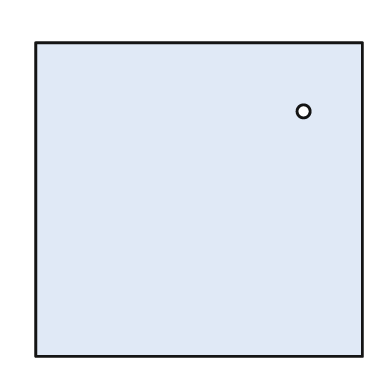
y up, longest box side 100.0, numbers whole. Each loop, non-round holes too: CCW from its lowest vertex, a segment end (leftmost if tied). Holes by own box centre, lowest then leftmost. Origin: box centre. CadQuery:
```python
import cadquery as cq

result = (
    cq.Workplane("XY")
    .moveTo(-50.0, -48.0)
    .lineTo(50.0, -48.0)
    .lineTo(50.0, 48.0)
    .lineTo(-50.0, 48.0)
    .close()
    .moveTo(32.0, 27.0)
    .circle(2.0)
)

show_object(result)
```